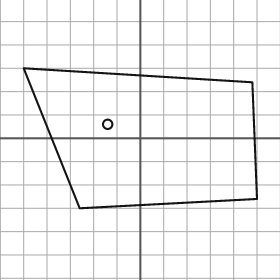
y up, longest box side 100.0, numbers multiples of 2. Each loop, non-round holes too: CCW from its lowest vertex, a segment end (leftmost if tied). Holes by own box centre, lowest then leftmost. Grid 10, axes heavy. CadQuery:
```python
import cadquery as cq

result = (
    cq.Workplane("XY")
    .moveTo(-26.0, -30.0)
    .lineTo(50.0, -26.0)
    .lineTo(48.0, 24.0)
    .lineTo(-50.0, 30.0)
    .close()
    .moveTo(-14.0, 6.0)
    .circle(2.0)
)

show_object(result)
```